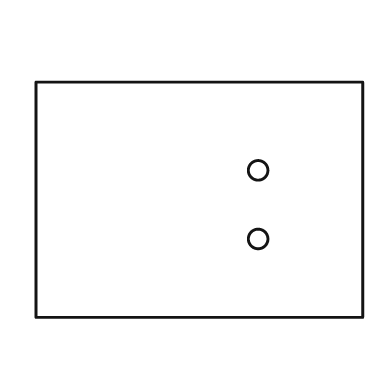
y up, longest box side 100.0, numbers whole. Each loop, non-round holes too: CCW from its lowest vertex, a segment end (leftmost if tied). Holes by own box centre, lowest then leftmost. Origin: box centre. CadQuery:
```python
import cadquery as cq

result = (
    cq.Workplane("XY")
    .moveTo(-50.0, -36.0)
    .lineTo(50.0, -36.0)
    .lineTo(50.0, 36.0)
    .lineTo(-50.0, 36.0)
    .close()
    .moveTo(18.0, -12.0)
    .circle(3.0)
    .moveTo(18.0, 9.0)
    .circle(3.0)
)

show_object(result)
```